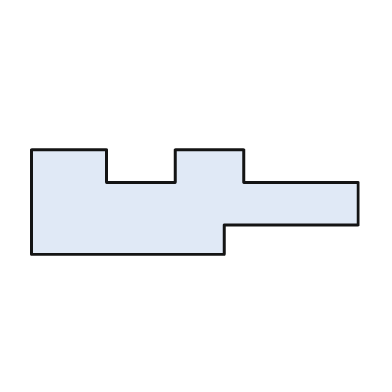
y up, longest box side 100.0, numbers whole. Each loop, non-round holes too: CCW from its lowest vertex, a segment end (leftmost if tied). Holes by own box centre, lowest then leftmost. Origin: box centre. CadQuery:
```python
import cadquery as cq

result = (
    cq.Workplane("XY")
    .moveTo(-50.0, -16.0)
    .lineTo(9.0, -16.0)
    .lineTo(9.0, -7.0)
    .lineTo(50.0, -7.0)
    .lineTo(50.0, 6.0)
    .lineTo(15.0, 6.0)
    .lineTo(15.0, 16.0)
    .lineTo(-6.0, 16.0)
    .lineTo(-6.0, 6.0)
    .lineTo(-27.0, 6.0)
    .lineTo(-27.0, 16.0)
    .lineTo(-50.0, 16.0)
    .close()
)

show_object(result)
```